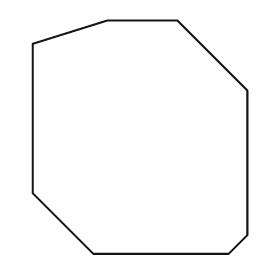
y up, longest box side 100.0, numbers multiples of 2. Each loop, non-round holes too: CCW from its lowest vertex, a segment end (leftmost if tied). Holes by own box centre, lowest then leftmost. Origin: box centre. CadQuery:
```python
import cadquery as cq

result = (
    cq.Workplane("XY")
    .moveTo(-20.0, -50.0)
    .lineTo(38.0, -50.0)
    .lineTo(46.0, -42.0)
    .lineTo(46.0, 20.0)
    .lineTo(16.0, 50.0)
    .lineTo(-14.0, 50.0)
    .lineTo(-46.0, 40.0)
    .lineTo(-46.0, -24.0)
    .close()
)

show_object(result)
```